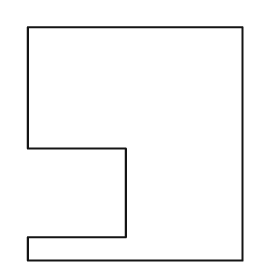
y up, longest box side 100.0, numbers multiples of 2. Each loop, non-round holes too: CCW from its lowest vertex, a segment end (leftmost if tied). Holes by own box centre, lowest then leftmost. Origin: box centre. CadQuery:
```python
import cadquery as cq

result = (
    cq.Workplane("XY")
    .moveTo(-46.0, -50.0)
    .lineTo(46.0, -50.0)
    .lineTo(46.0, 50.0)
    .lineTo(-46.0, 50.0)
    .lineTo(-46.0, -2.0)
    .lineTo(-4.0, -2.0)
    .lineTo(-4.0, -40.0)
    .lineTo(-46.0, -40.0)
    .close()
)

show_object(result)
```